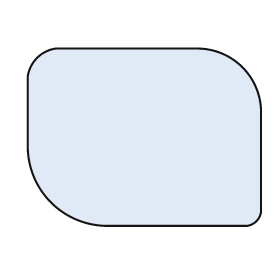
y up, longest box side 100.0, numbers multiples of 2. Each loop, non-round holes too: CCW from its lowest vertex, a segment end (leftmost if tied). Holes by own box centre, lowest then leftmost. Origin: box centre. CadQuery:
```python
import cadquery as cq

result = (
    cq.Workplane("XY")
    .moveTo(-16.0, -38.0)
    .lineTo(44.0, -38.0)
    .threePointArc((48.0, -36.0), (50.0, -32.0))
    .lineTo(50.0, 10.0)
    .threePointArc((42.0, 30.0), (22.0, 38.0))
    .lineTo(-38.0, 38.0)
    .threePointArc((-46.0, 34.0), (-50.0, 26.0))
    .lineTo(-50.0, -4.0)
    .threePointArc((-40.0, -28.0), (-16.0, -38.0))
    .close()
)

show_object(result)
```